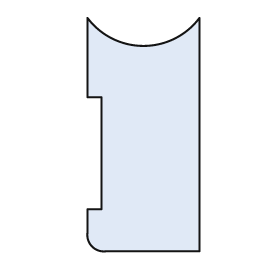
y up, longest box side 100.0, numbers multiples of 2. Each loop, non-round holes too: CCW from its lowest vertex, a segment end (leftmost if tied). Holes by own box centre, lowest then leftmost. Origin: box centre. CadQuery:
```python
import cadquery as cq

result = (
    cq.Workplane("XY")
    .moveTo(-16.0, -50.0)
    .lineTo(24.0, -50.0)
    .lineTo(24.0, 50.0)
    .threePointArc((0.0, 38.0), (-24.0, 50.0))
    .lineTo(-24.0, 16.0)
    .lineTo(-18.0, 16.0)
    .lineTo(-18.0, -32.0)
    .lineTo(-24.0, -32.0)
    .lineTo(-24.0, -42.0)
    .threePointArc((-22.0, -48.0), (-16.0, -50.0))
    .close()
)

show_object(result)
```